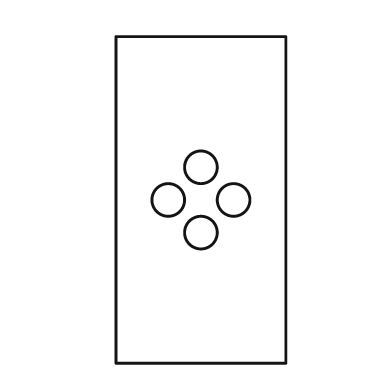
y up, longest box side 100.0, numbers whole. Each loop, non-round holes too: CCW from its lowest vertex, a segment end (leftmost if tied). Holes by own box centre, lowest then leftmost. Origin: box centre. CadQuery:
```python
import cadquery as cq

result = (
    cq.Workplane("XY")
    .moveTo(-26.0, -50.0)
    .lineTo(26.0, -50.0)
    .lineTo(26.0, 50.0)
    .lineTo(-26.0, 50.0)
    .close()
    .moveTo(0.0, -10.0)
    .circle(5.0)
    .moveTo(-10.0, 0.0)
    .circle(5.0)
    .moveTo(10.0, 0.0)
    .circle(5.0)
    .moveTo(0.0, 10.0)
    .circle(5.0)
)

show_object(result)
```